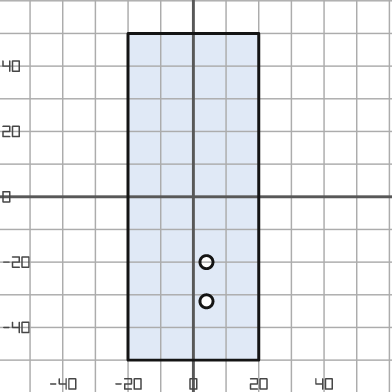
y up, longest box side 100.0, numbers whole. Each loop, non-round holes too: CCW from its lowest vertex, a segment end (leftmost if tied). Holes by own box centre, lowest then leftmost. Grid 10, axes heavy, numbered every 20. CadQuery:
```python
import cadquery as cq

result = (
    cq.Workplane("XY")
    .moveTo(-20.0, -50.0)
    .lineTo(20.0, -50.0)
    .lineTo(20.0, 50.0)
    .lineTo(-20.0, 50.0)
    .close()
    .moveTo(4.0, -32.0)
    .circle(2.0)
    .moveTo(4.0, -20.0)
    .circle(2.0)
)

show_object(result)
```